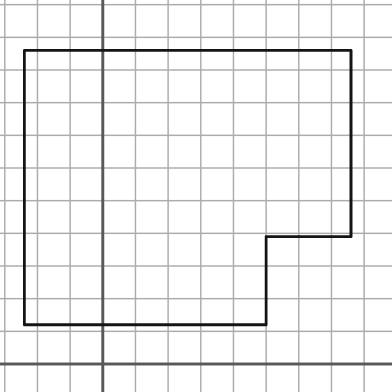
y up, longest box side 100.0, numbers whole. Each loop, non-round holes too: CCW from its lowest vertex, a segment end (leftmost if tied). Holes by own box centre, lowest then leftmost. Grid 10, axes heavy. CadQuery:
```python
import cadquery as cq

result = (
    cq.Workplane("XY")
    .moveTo(-24.0, 12.0)
    .lineTo(50.0, 12.0)
    .lineTo(50.0, 39.0)
    .lineTo(76.0, 39.0)
    .lineTo(76.0, 96.0)
    .lineTo(-24.0, 96.0)
    .close()
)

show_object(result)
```